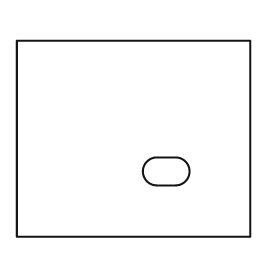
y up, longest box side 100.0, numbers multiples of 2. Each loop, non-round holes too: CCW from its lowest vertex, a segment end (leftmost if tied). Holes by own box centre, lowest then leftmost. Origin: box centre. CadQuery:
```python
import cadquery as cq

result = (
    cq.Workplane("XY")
    .moveTo(-50.0, -42.0)
    .lineTo(50.0, -42.0)
    .lineTo(50.0, 42.0)
    .lineTo(-50.0, 42.0)
    .close()
    .moveTo(10.0, -20.0)
    .lineTo(18.0, -20.0)
    .threePointArc((24.0, -14.0), (18.0, -8.0))
    .lineTo(10.0, -8.0)
    .threePointArc((4.0, -14.0), (10.0, -20.0))
    .close()
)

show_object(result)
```